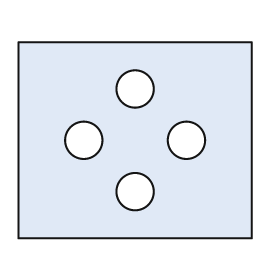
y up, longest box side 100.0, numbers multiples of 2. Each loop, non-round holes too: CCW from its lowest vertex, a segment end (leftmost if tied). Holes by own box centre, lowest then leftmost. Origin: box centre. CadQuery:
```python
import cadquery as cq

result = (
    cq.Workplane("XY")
    .moveTo(-50.0, -42.0)
    .lineTo(50.0, -42.0)
    .lineTo(50.0, 42.0)
    .lineTo(-50.0, 42.0)
    .close()
    .moveTo(0.0, -22.0)
    .circle(8.0)
    .moveTo(-22.0, 0.0)
    .circle(8.0)
    .moveTo(22.0, 0.0)
    .circle(8.0)
    .moveTo(0.0, 22.0)
    .circle(8.0)
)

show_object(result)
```